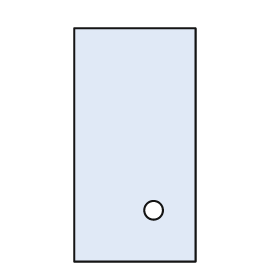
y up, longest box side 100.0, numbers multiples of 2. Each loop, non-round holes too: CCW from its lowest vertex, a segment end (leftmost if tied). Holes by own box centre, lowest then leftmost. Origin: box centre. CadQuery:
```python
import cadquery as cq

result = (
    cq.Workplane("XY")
    .moveTo(-26.0, -50.0)
    .lineTo(26.0, -50.0)
    .lineTo(26.0, 50.0)
    .lineTo(-26.0, 50.0)
    .close()
    .moveTo(8.0, -28.0)
    .circle(4.0)
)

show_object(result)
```